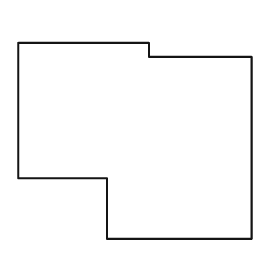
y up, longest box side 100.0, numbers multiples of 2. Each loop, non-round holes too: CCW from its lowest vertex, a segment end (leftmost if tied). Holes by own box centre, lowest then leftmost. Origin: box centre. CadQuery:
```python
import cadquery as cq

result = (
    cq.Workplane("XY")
    .moveTo(-12.0, -42.0)
    .lineTo(50.0, -42.0)
    .lineTo(50.0, 36.0)
    .lineTo(6.0, 36.0)
    .lineTo(6.0, 42.0)
    .lineTo(-50.0, 42.0)
    .lineTo(-50.0, -16.0)
    .lineTo(-12.0, -16.0)
    .close()
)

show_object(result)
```